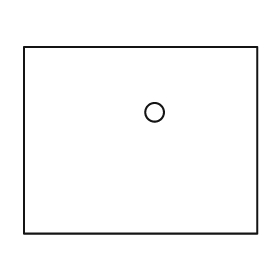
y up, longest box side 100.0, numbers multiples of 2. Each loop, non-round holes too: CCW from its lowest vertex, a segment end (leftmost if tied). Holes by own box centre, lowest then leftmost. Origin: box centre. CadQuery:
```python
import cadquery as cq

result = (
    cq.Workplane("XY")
    .moveTo(-50.0, -40.0)
    .lineTo(50.0, -40.0)
    .lineTo(50.0, 40.0)
    .lineTo(-50.0, 40.0)
    .close()
    .moveTo(6.0, 12.0)
    .circle(4.0)
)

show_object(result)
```